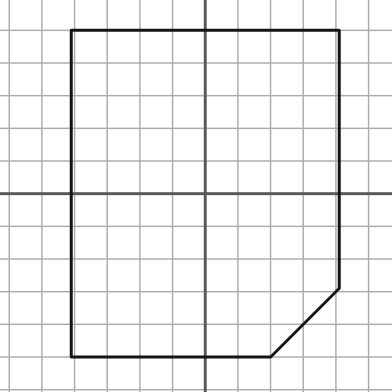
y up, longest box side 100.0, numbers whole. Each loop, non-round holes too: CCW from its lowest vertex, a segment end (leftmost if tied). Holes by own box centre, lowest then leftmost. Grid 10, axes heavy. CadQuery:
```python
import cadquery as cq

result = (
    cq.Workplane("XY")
    .moveTo(-41.0, -50.0)
    .lineTo(20.0, -50.0)
    .lineTo(41.0, -29.0)
    .lineTo(41.0, 50.0)
    .lineTo(-41.0, 50.0)
    .close()
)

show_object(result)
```